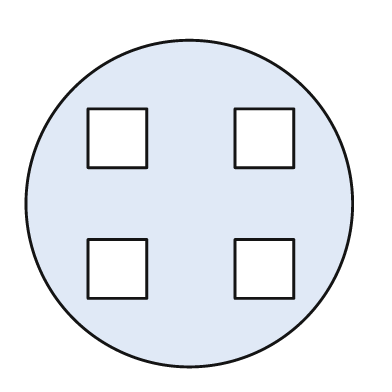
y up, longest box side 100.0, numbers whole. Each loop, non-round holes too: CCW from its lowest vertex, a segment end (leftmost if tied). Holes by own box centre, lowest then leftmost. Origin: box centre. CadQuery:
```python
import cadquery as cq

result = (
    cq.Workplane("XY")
    .moveTo(0.0, 0.0)
    .circle(50.0)
    .moveTo(-31.0, -29.0)
    .lineTo(-13.0, -29.0)
    .lineTo(-13.0, -11.0)
    .lineTo(-31.0, -11.0)
    .close()
    .moveTo(14.0, -29.0)
    .lineTo(32.0, -29.0)
    .lineTo(32.0, -11.0)
    .lineTo(14.0, -11.0)
    .close()
    .moveTo(-31.0, 11.0)
    .lineTo(-13.0, 11.0)
    .lineTo(-13.0, 29.0)
    .lineTo(-31.0, 29.0)
    .close()
    .moveTo(14.0, 11.0)
    .lineTo(32.0, 11.0)
    .lineTo(32.0, 29.0)
    .lineTo(14.0, 29.0)
    .close()
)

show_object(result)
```